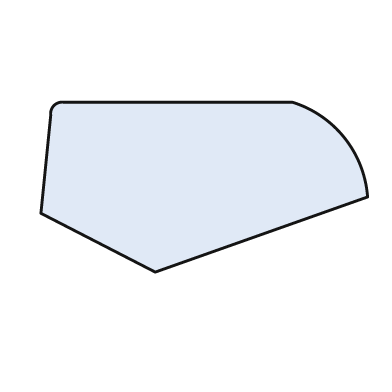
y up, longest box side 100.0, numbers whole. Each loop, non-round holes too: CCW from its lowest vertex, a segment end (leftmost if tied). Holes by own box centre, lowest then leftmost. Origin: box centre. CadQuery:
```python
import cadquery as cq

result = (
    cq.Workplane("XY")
    .moveTo(-15.0, -26.0)
    .lineTo(50.0, -3.0)
    .threePointArc((43.0, 15.0), (27.0, 26.0))
    .lineTo(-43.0, 26.0)
    .threePointArc((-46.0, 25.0), (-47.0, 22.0))
    .lineTo(-50.0, -8.0)
    .close()
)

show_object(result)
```